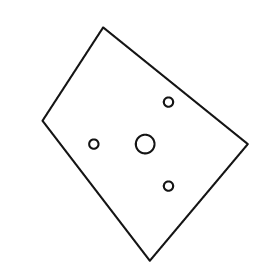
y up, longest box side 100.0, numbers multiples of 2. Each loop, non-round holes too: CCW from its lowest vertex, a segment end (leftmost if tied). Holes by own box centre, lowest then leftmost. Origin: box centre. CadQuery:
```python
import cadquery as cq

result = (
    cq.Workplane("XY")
    .moveTo(2.0, -50.0)
    .lineTo(44.0, 0.0)
    .lineTo(-18.0, 50.0)
    .lineTo(-44.0, 10.0)
    .close()
    .moveTo(10.0, -18.0)
    .circle(2.0)
    .moveTo(-22.0, 0.0)
    .circle(2.0)
    .moveTo(0.0, 0.0)
    .circle(4.0)
    .moveTo(10.0, 18.0)
    .circle(2.0)
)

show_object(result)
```